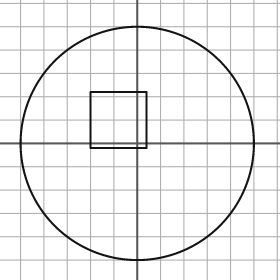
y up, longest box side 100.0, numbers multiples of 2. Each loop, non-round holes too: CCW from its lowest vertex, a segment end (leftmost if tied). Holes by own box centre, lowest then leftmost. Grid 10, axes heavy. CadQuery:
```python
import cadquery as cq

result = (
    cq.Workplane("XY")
    .moveTo(0.0, 0.0)
    .circle(50.0)
    .moveTo(-20.0, -2.0)
    .lineTo(4.0, -2.0)
    .lineTo(4.0, 22.0)
    .lineTo(-20.0, 22.0)
    .close()
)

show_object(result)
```